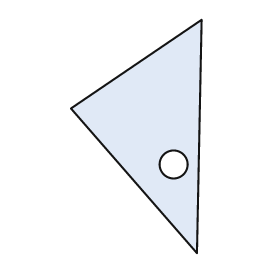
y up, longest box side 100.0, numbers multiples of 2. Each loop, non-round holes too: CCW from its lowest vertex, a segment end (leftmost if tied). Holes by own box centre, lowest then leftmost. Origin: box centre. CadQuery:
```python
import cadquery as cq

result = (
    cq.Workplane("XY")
    .moveTo(26.0, -50.0)
    .lineTo(28.0, 50.0)
    .lineTo(-28.0, 12.0)
    .close()
    .moveTo(16.0, -12.0)
    .circle(6.0)
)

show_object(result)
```